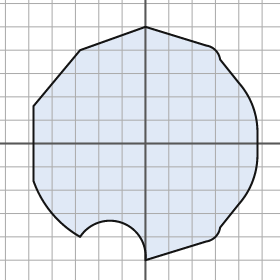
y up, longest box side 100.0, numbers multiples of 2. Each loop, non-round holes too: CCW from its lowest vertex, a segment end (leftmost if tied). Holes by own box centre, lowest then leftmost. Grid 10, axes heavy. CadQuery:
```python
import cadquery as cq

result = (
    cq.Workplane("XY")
    .moveTo(0.0, -50.0)
    .lineTo(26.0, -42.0)
    .threePointArc((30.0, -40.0), (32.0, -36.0))
    .lineTo(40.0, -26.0)
    .threePointArc((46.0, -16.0), (48.0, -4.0))
    .lineTo(48.0, 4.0)
    .threePointArc((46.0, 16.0), (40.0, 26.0))
    .lineTo(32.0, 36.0)
    .threePointArc((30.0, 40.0), (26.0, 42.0))
    .lineTo(0.0, 50.0)
    .lineTo(-28.0, 40.0)
    .lineTo(-48.0, 16.0)
    .lineTo(-48.0, -16.0)
    .threePointArc((-40.0, -30.0), (-28.0, -40.0))
    .threePointArc((-10.0, -34.0), (0.0, -50.0))
    .close()
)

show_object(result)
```